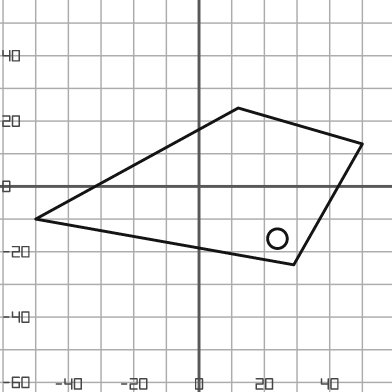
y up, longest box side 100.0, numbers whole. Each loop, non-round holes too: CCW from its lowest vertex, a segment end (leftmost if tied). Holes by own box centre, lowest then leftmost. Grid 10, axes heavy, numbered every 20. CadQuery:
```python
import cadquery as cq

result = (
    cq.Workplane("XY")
    .moveTo(29.0, -24.0)
    .lineTo(50.0, 13.0)
    .lineTo(12.0, 24.0)
    .lineTo(-50.0, -10.0)
    .close()
    .moveTo(24.0, -16.0)
    .circle(3.0)
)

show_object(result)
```